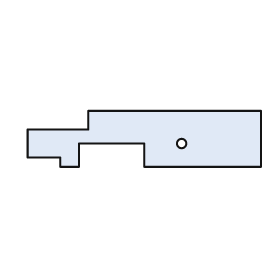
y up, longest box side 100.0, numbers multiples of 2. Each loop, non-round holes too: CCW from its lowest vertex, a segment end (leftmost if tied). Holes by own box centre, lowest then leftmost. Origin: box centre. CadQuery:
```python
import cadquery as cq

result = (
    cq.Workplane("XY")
    .moveTo(-36.0, -12.0)
    .lineTo(-28.0, -12.0)
    .lineTo(-28.0, -2.0)
    .lineTo(0.0, -2.0)
    .lineTo(0.0, -12.0)
    .lineTo(50.0, -12.0)
    .lineTo(50.0, 12.0)
    .lineTo(-24.0, 12.0)
    .lineTo(-24.0, 4.0)
    .lineTo(-50.0, 4.0)
    .lineTo(-50.0, -8.0)
    .lineTo(-36.0, -8.0)
    .close()
    .moveTo(16.0, -2.0)
    .circle(2.0)
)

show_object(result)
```